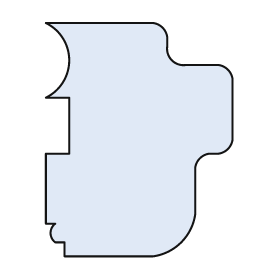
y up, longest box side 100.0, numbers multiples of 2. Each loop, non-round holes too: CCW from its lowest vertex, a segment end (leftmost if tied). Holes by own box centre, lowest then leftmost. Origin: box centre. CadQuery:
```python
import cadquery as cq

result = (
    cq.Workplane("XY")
    .moveTo(-32.0, -50.0)
    .lineTo(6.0, -50.0)
    .threePointArc((18.0, -44.0), (24.0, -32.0))
    .lineTo(24.0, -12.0)
    .threePointArc((26.0, -8.0), (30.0, -6.0))
    .lineTo(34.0, -6.0)
    .threePointArc((38.0, -4.0), (40.0, 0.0))
    .lineTo(40.0, 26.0)
    .threePointArc((38.0, 30.0), (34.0, 32.0))
    .lineTo(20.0, 32.0)
    .threePointArc((14.0, 34.0), (12.0, 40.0))
    .lineTo(12.0, 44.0)
    .threePointArc((10.0, 48.0), (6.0, 50.0))
    .lineTo(-40.0, 50.0)
    .threePointArc((-30.0, 34.0), (-40.0, 18.0))
    .lineTo(-30.0, 18.0)
    .lineTo(-30.0, -6.0)
    .lineTo(-40.0, -6.0)
    .lineTo(-40.0, -36.0)
    .lineTo(-36.0, -36.0)
    .threePointArc((-38.0, -40.0), (-36.0, -44.0))
    .lineTo(-32.0, -44.0)
    .close()
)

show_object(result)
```